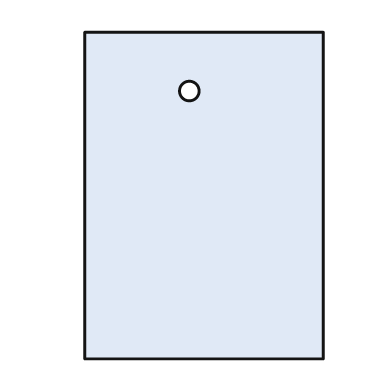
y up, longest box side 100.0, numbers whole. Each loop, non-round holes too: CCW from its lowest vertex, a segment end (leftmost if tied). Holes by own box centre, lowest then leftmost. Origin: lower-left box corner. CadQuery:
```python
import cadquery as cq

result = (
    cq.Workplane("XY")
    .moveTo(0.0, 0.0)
    .lineTo(73.0, 0.0)
    .lineTo(73.0, 100.0)
    .lineTo(0.0, 100.0)
    .close()
    .moveTo(32.0, 82.0)
    .circle(3.0)
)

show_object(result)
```